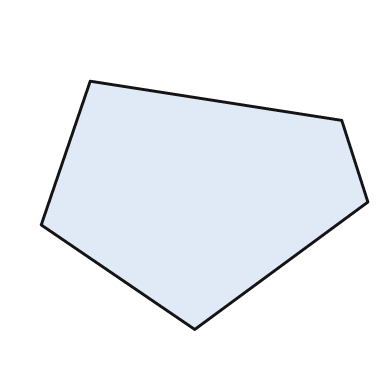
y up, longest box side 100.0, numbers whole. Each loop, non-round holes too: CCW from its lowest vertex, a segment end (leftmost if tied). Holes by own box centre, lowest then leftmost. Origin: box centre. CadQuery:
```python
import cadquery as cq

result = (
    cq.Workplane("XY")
    .moveTo(-3.0, -38.0)
    .lineTo(50.0, 1.0)
    .lineTo(42.0, 26.0)
    .lineTo(-35.0, 38.0)
    .lineTo(-50.0, -6.0)
    .close()
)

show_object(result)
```